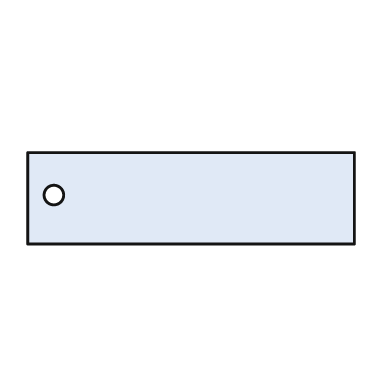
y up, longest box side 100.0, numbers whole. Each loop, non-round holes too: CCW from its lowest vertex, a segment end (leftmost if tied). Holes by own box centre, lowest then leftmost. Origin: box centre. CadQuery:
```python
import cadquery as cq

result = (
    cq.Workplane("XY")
    .moveTo(-50.0, -14.0)
    .lineTo(50.0, -14.0)
    .lineTo(50.0, 14.0)
    .lineTo(-50.0, 14.0)
    .close()
    .moveTo(-42.0, 1.0)
    .circle(3.0)
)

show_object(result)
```